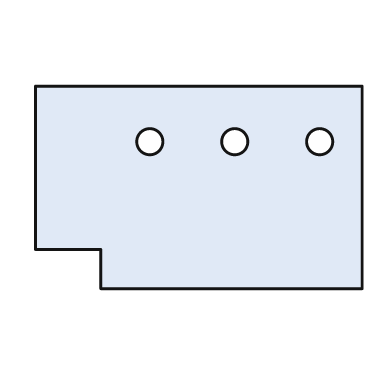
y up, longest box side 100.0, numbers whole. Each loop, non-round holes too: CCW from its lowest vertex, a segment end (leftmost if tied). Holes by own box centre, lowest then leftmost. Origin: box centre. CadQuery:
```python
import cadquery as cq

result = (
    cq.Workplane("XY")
    .moveTo(-30.0, -31.0)
    .lineTo(50.0, -31.0)
    .lineTo(50.0, 31.0)
    .lineTo(-50.0, 31.0)
    .lineTo(-50.0, -19.0)
    .lineTo(-30.0, -19.0)
    .close()
    .moveTo(-15.0, 14.0)
    .circle(4.0)
    .moveTo(11.0, 14.0)
    .circle(4.0)
    .moveTo(37.0, 14.0)
    .circle(4.0)
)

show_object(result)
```